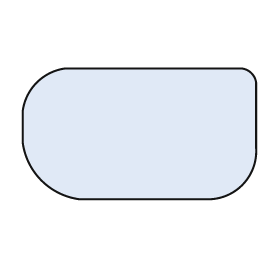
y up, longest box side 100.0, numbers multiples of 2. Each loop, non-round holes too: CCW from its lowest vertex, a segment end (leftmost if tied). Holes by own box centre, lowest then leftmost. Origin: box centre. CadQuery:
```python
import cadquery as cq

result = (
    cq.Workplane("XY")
    .moveTo(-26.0, -28.0)
    .lineTo(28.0, -28.0)
    .threePointArc((44.0, -22.0), (50.0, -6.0))
    .lineTo(50.0, 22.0)
    .threePointArc((48.0, 26.0), (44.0, 28.0))
    .lineTo(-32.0, 28.0)
    .threePointArc((-44.0, 22.0), (-50.0, 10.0))
    .lineTo(-50.0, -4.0)
    .threePointArc((-42.0, -20.0), (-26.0, -28.0))
    .close()
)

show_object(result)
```